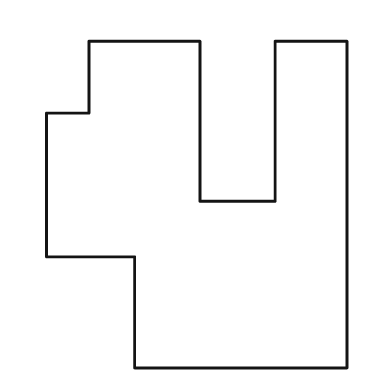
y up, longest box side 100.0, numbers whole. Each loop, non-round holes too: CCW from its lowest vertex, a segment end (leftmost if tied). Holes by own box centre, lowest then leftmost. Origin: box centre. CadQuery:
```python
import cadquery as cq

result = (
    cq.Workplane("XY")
    .moveTo(-19.0, -50.0)
    .lineTo(46.0, -50.0)
    .lineTo(46.0, 50.0)
    .lineTo(24.0, 50.0)
    .lineTo(24.0, 1.0)
    .lineTo(1.0, 1.0)
    .lineTo(1.0, 50.0)
    .lineTo(-33.0, 50.0)
    .lineTo(-33.0, 28.0)
    .lineTo(-46.0, 28.0)
    .lineTo(-46.0, -16.0)
    .lineTo(-19.0, -16.0)
    .close()
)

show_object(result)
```